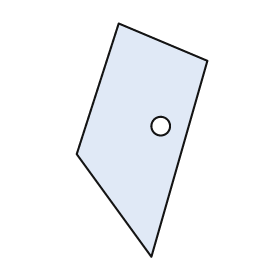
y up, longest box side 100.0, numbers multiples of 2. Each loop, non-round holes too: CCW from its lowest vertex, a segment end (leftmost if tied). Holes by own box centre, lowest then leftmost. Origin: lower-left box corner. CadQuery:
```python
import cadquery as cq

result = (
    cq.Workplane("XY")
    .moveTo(32.0, 0.0)
    .lineTo(56.0, 84.0)
    .lineTo(18.0, 100.0)
    .lineTo(0.0, 44.0)
    .close()
    .moveTo(36.0, 56.0)
    .circle(4.0)
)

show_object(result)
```